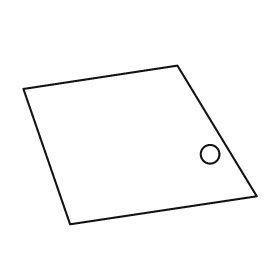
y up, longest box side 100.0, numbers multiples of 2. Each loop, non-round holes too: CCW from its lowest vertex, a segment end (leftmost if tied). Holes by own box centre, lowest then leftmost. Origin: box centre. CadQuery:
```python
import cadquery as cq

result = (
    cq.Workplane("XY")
    .moveTo(-30.0, -34.0)
    .lineTo(50.0, -22.0)
    .lineTo(16.0, 34.0)
    .lineTo(-50.0, 24.0)
    .close()
    .moveTo(30.0, -4.0)
    .circle(4.0)
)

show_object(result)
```